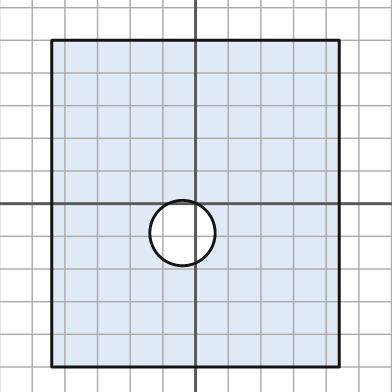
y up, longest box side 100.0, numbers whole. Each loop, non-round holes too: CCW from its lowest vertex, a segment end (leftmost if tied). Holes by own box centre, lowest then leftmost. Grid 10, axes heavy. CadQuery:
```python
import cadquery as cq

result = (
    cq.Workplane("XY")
    .moveTo(-44.0, -50.0)
    .lineTo(44.0, -50.0)
    .lineTo(44.0, 50.0)
    .lineTo(-44.0, 50.0)
    .close()
    .moveTo(-4.0, -9.0)
    .circle(10.0)
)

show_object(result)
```